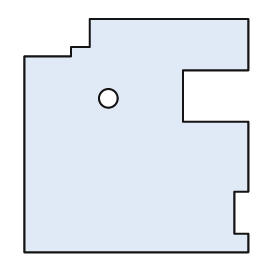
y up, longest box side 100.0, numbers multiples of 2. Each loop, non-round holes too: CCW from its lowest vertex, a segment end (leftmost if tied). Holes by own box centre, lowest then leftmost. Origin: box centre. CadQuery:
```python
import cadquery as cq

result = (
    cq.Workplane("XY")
    .moveTo(-48.0, -50.0)
    .lineTo(48.0, -50.0)
    .lineTo(48.0, -42.0)
    .lineTo(42.0, -42.0)
    .lineTo(42.0, -24.0)
    .lineTo(48.0, -24.0)
    .lineTo(48.0, 6.0)
    .lineTo(20.0, 6.0)
    .lineTo(20.0, 28.0)
    .lineTo(48.0, 28.0)
    .lineTo(48.0, 50.0)
    .lineTo(-20.0, 50.0)
    .lineTo(-20.0, 38.0)
    .lineTo(-28.0, 38.0)
    .lineTo(-28.0, 34.0)
    .lineTo(-48.0, 34.0)
    .close()
    .moveTo(-12.0, 16.0)
    .circle(4.0)
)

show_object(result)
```